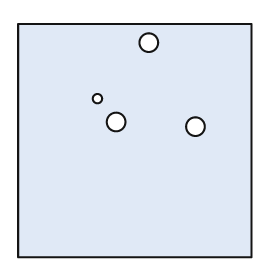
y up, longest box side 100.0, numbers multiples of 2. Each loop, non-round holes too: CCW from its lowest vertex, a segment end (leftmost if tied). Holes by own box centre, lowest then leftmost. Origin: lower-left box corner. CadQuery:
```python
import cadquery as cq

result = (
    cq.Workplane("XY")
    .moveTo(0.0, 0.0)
    .lineTo(100.0, 0.0)
    .lineTo(100.0, 100.0)
    .lineTo(0.0, 100.0)
    .close()
    .moveTo(76.0, 56.0)
    .circle(4.0)
    .moveTo(42.0, 58.0)
    .circle(4.0)
    .moveTo(34.0, 68.0)
    .circle(2.0)
    .moveTo(56.0, 92.0)
    .circle(4.0)
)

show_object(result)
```